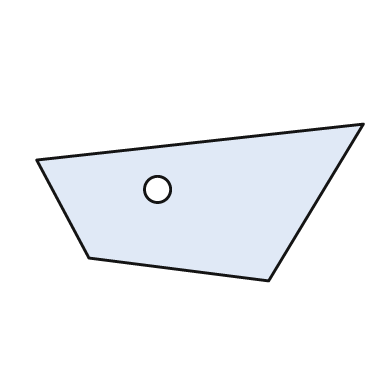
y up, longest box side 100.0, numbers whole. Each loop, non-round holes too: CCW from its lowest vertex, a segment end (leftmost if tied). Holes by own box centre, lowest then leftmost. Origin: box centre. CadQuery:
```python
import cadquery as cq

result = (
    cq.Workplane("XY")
    .moveTo(21.0, -24.0)
    .lineTo(50.0, 24.0)
    .lineTo(-50.0, 13.0)
    .lineTo(-34.0, -17.0)
    .close()
    .moveTo(-13.0, 4.0)
    .circle(4.0)
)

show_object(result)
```